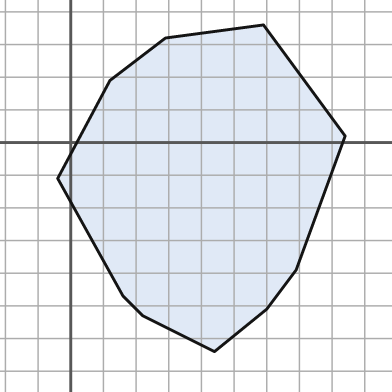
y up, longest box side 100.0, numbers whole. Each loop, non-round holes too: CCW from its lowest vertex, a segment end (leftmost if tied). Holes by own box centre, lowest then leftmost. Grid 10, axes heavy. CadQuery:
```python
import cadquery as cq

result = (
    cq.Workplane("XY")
    .moveTo(44.0, -64.0)
    .lineTo(60.0, -51.0)
    .lineTo(69.0, -39.0)
    .lineTo(84.0, 2.0)
    .lineTo(59.0, 36.0)
    .lineTo(29.0, 32.0)
    .lineTo(12.0, 19.0)
    .lineTo(-4.0, -11.0)
    .lineTo(16.0, -47.0)
    .lineTo(22.0, -53.0)
    .close()
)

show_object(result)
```